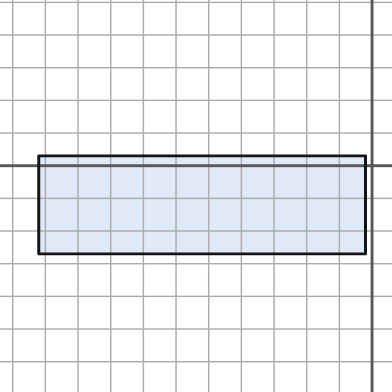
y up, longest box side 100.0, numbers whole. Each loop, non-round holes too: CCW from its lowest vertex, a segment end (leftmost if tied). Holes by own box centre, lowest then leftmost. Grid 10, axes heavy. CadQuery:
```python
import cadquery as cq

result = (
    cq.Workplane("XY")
    .moveTo(-102.0, -27.0)
    .lineTo(-2.0, -27.0)
    .lineTo(-2.0, 3.0)
    .lineTo(-102.0, 3.0)
    .close()
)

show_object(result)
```